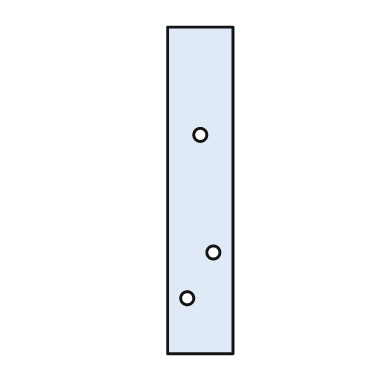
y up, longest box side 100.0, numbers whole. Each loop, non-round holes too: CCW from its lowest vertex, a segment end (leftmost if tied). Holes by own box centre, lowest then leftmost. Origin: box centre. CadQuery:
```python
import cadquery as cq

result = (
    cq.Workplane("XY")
    .moveTo(-10.0, -50.0)
    .lineTo(10.0, -50.0)
    .lineTo(10.0, 50.0)
    .lineTo(-10.0, 50.0)
    .close()
    .moveTo(-4.0, -33.0)
    .circle(2.0)
    .moveTo(4.0, -19.0)
    .circle(2.0)
    .moveTo(0.0, 17.0)
    .circle(2.0)
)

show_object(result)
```